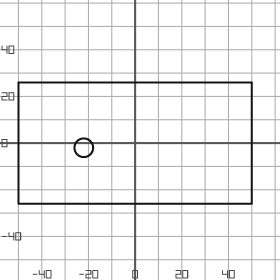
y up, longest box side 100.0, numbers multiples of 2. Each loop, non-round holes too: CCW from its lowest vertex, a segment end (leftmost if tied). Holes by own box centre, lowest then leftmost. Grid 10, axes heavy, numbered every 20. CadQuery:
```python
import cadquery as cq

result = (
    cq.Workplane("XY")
    .moveTo(-50.0, -26.0)
    .lineTo(50.0, -26.0)
    .lineTo(50.0, 26.0)
    .lineTo(-50.0, 26.0)
    .close()
    .moveTo(-22.0, -2.0)
    .circle(4.0)
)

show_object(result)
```